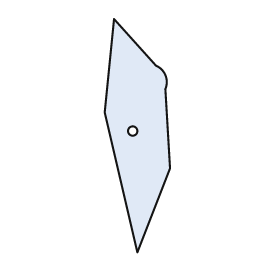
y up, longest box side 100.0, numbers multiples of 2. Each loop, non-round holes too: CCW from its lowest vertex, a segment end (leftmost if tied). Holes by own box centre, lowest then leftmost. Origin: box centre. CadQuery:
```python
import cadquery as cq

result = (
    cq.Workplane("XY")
    .moveTo(0.0, -50.0)
    .lineTo(14.0, -14.0)
    .lineTo(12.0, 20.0)
    .threePointArc((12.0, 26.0), (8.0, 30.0))
    .lineTo(-10.0, 50.0)
    .lineTo(-14.0, 10.0)
    .close()
    .moveTo(-2.0, 2.0)
    .circle(2.0)
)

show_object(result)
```